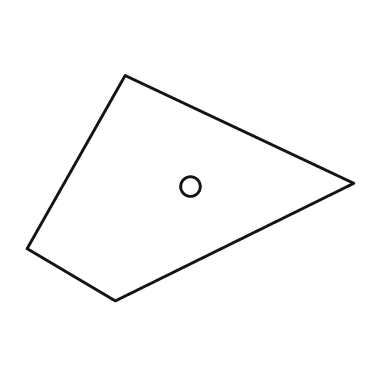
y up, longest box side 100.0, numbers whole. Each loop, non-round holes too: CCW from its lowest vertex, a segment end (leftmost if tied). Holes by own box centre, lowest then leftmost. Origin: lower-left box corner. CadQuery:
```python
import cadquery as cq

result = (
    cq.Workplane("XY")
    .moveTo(27.0, 0.0)
    .lineTo(100.0, 36.0)
    .lineTo(30.0, 69.0)
    .lineTo(0.0, 16.0)
    .close()
    .moveTo(50.0, 35.0)
    .circle(3.0)
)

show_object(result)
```